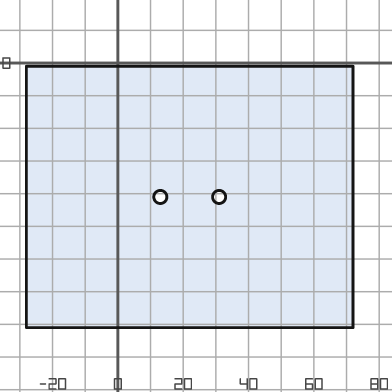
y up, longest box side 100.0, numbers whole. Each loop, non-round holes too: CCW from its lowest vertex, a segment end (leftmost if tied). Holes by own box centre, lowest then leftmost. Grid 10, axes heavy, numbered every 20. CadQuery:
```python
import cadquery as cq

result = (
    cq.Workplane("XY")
    .moveTo(-28.0, -81.0)
    .lineTo(72.0, -81.0)
    .lineTo(72.0, -1.0)
    .lineTo(-28.0, -1.0)
    .close()
    .moveTo(13.0, -41.0)
    .circle(2.0)
    .moveTo(31.0, -41.0)
    .circle(2.0)
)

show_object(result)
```